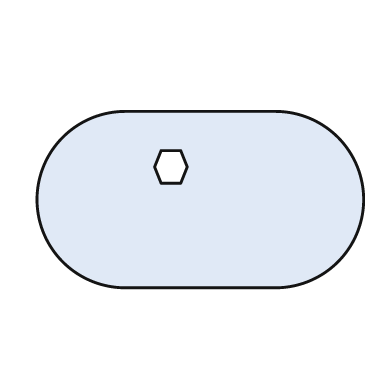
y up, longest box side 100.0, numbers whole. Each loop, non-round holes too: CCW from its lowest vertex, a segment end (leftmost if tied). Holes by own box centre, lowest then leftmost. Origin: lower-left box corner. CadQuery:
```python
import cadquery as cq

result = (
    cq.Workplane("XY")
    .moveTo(27.0, 0.0)
    .lineTo(73.0, 0.0)
    .threePointArc((100.0, 27.0), (73.0, 54.0))
    .lineTo(27.0, 54.0)
    .threePointArc((0.0, 27.0), (27.0, 0.0))
    .close()
    .moveTo(38.0, 32.0)
    .lineTo(44.0, 32.0)
    .lineTo(46.0, 37.0)
    .lineTo(44.0, 42.0)
    .lineTo(38.0, 42.0)
    .lineTo(36.0, 37.0)
    .close()
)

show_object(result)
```